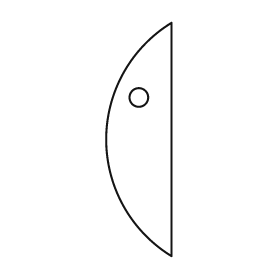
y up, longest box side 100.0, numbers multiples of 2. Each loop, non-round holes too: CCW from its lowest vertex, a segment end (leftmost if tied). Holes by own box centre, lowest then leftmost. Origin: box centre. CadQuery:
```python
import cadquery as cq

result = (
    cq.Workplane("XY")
    .moveTo(14.0, -50.0)
    .lineTo(14.0, 50.0)
    .threePointArc((-14.0, 0.0), (14.0, -50.0))
    .close()
    .moveTo(0.0, 18.0)
    .circle(4.0)
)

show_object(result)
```